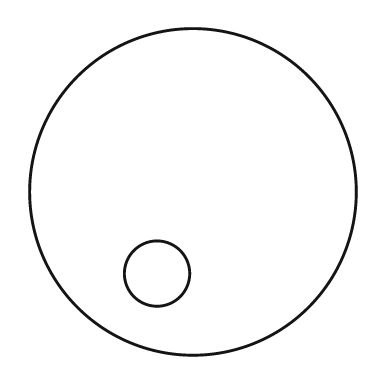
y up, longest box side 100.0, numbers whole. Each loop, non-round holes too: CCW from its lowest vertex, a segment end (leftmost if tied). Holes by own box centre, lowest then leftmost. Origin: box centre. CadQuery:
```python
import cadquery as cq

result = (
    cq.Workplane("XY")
    .moveTo(0.0, 0.0)
    .circle(50.0)
    .moveTo(-11.0, -25.0)
    .circle(10.0)
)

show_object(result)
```